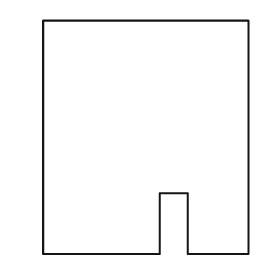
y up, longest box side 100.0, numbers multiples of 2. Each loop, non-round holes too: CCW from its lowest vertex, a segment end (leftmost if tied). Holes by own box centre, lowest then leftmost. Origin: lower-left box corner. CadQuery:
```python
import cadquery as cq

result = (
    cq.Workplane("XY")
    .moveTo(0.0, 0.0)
    .lineTo(50.0, 0.0)
    .lineTo(50.0, 26.0)
    .lineTo(62.0, 26.0)
    .lineTo(62.0, 0.0)
    .lineTo(88.0, 0.0)
    .lineTo(88.0, 100.0)
    .lineTo(0.0, 100.0)
    .close()
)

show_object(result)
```